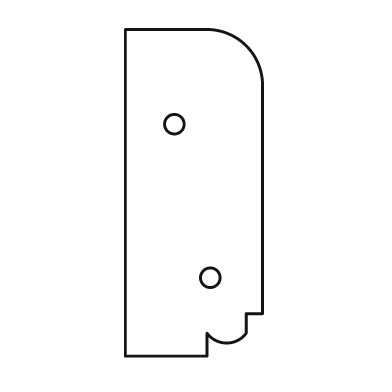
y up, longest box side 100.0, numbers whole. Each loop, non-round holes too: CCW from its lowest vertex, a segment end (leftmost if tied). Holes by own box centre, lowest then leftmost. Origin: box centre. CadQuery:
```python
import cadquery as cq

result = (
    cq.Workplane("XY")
    .moveTo(-21.0, -50.0)
    .lineTo(4.0, -50.0)
    .lineTo(4.0, -43.0)
    .threePointArc((10.0, -46.0), (16.0, -43.0))
    .lineTo(16.0, -37.0)
    .lineTo(21.0, -37.0)
    .lineTo(21.0, 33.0)
    .threePointArc((16.0, 45.0), (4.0, 50.0))
    .lineTo(-21.0, 50.0)
    .close()
    .moveTo(5.0, -26.0)
    .circle(3.0)
    .moveTo(-6.0, 21.0)
    .circle(3.0)
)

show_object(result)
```